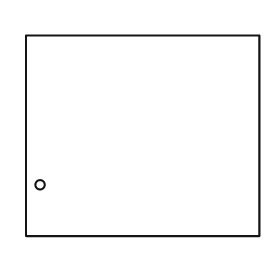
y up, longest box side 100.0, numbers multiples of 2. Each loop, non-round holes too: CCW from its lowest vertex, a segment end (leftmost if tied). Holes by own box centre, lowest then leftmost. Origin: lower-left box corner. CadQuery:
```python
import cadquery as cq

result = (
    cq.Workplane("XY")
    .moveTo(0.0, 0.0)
    .lineTo(100.0, 0.0)
    .lineTo(100.0, 86.0)
    .lineTo(0.0, 86.0)
    .close()
    .moveTo(6.0, 22.0)
    .circle(2.0)
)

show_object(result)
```